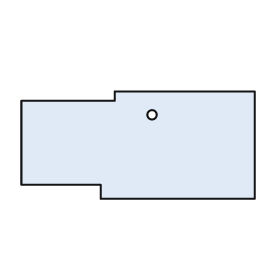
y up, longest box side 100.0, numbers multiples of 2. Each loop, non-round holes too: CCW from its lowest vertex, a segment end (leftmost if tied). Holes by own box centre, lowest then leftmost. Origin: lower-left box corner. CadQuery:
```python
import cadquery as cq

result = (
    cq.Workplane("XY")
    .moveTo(34.0, 0.0)
    .lineTo(100.0, 0.0)
    .lineTo(100.0, 46.0)
    .lineTo(40.0, 46.0)
    .lineTo(40.0, 42.0)
    .lineTo(0.0, 42.0)
    .lineTo(0.0, 6.0)
    .lineTo(34.0, 6.0)
    .close()
    .moveTo(56.0, 36.0)
    .circle(2.0)
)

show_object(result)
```